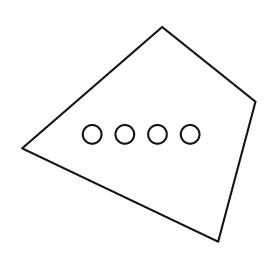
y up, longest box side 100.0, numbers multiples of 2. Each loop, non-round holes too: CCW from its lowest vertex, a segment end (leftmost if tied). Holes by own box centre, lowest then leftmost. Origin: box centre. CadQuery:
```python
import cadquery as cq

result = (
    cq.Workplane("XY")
    .moveTo(34.0, -46.0)
    .lineTo(50.0, 14.0)
    .lineTo(10.0, 46.0)
    .lineTo(-50.0, -6.0)
    .close()
    .moveTo(-20.0, 0.0)
    .circle(4.0)
    .moveTo(-6.0, 0.0)
    .circle(4.0)
    .moveTo(8.0, 0.0)
    .circle(4.0)
    .moveTo(22.0, 0.0)
    .circle(4.0)
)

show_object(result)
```